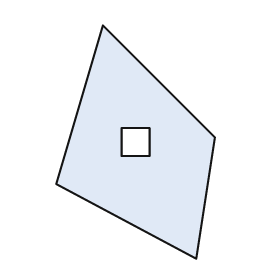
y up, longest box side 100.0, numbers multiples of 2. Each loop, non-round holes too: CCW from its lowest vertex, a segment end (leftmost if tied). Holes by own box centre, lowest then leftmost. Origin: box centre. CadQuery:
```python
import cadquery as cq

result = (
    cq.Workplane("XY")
    .moveTo(26.0, -50.0)
    .lineTo(34.0, 2.0)
    .lineTo(-14.0, 50.0)
    .lineTo(-34.0, -18.0)
    .close()
    .moveTo(-6.0, -6.0)
    .lineTo(6.0, -6.0)
    .lineTo(6.0, 6.0)
    .lineTo(-6.0, 6.0)
    .close()
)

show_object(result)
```